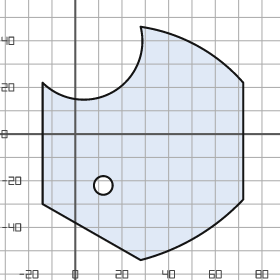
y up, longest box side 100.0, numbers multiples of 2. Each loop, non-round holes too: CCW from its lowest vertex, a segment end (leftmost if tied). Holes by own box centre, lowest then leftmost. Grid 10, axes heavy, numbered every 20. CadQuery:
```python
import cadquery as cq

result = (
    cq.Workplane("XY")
    .moveTo(28.0, -54.0)
    .threePointArc((52.0, -44.0), (72.0, -28.0))
    .lineTo(72.0, 22.0)
    .threePointArc((52.0, 38.0), (28.0, 46.0))
    .threePointArc((16.0, 18.0), (-14.0, 22.0))
    .lineTo(-14.0, -30.0)
    .close()
    .moveTo(12.0, -22.0)
    .circle(4.0)
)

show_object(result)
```